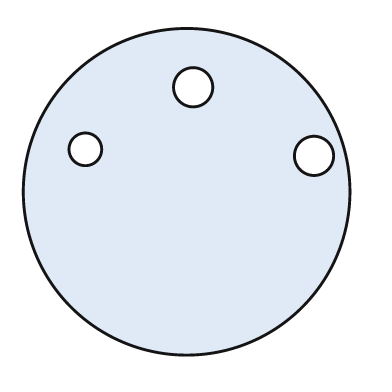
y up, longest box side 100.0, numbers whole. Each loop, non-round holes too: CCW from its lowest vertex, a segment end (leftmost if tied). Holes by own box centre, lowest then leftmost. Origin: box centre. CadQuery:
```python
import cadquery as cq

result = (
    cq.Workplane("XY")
    .moveTo(0.0, 0.0)
    .circle(50.0)
    .moveTo(39.0, 11.0)
    .circle(6.0)
    .moveTo(-31.0, 13.0)
    .circle(5.0)
    .moveTo(2.0, 32.0)
    .circle(6.0)
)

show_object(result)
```